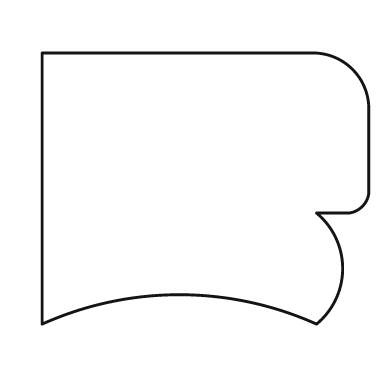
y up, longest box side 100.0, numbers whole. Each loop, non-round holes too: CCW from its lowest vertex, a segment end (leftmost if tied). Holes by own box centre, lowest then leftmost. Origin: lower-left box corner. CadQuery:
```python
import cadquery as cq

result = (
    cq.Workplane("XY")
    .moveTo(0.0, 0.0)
    .threePointArc((42.0, 9.0), (84.0, 0.0))
    .threePointArc((92.0, 17.0), (84.0, 34.0))
    .lineTo(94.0, 34.0)
    .threePointArc((98.0, 36.0), (100.0, 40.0))
    .lineTo(100.0, 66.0)
    .threePointArc((95.0, 78.0), (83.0, 83.0))
    .lineTo(0.0, 83.0)
    .close()
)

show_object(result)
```